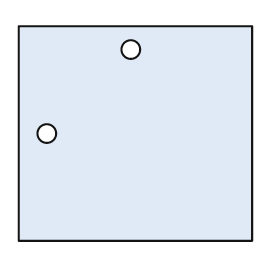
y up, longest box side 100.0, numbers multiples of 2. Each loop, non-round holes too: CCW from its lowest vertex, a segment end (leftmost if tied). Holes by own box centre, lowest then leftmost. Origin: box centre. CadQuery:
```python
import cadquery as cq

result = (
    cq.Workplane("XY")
    .moveTo(-50.0, -46.0)
    .lineTo(50.0, -46.0)
    .lineTo(50.0, 46.0)
    .lineTo(-50.0, 46.0)
    .close()
    .moveTo(-38.0, 0.0)
    .circle(4.0)
    .moveTo(-2.0, 36.0)
    .circle(4.0)
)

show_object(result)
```